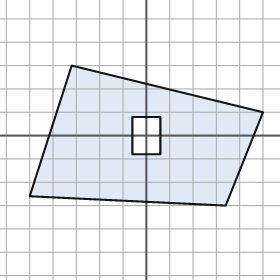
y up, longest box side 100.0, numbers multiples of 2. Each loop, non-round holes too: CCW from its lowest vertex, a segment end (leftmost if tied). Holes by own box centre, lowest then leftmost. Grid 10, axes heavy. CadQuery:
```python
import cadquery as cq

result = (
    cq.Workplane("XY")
    .moveTo(34.0, -30.0)
    .lineTo(50.0, 10.0)
    .lineTo(-32.0, 30.0)
    .lineTo(-50.0, -26.0)
    .close()
    .moveTo(-6.0, -8.0)
    .lineTo(6.0, -8.0)
    .lineTo(6.0, 8.0)
    .lineTo(-6.0, 8.0)
    .close()
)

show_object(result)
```